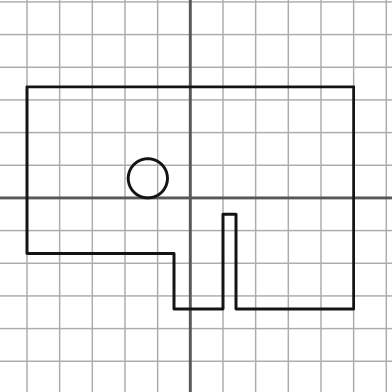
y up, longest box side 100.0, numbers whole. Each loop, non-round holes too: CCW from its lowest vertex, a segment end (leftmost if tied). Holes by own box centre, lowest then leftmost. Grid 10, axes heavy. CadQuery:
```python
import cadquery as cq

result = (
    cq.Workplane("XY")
    .moveTo(-5.0, -34.0)
    .lineTo(10.0, -34.0)
    .lineTo(10.0, -5.0)
    .lineTo(14.0, -5.0)
    .lineTo(14.0, -34.0)
    .lineTo(50.0, -34.0)
    .lineTo(50.0, 34.0)
    .lineTo(-50.0, 34.0)
    .lineTo(-50.0, -17.0)
    .lineTo(-5.0, -17.0)
    .close()
    .moveTo(-13.0, 6.0)
    .circle(6.0)
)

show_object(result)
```